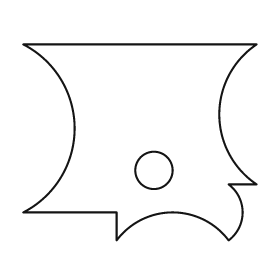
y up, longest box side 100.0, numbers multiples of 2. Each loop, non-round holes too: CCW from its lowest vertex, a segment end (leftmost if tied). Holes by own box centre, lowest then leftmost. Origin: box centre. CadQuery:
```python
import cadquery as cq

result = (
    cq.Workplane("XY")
    .moveTo(-10.0, -42.0)
    .threePointArc((14.0, -30.0), (38.0, -42.0))
    .threePointArc((44.0, -30.0), (38.0, -18.0))
    .lineTo(50.0, -18.0)
    .threePointArc((34.0, 12.0), (50.0, 42.0))
    .lineTo(-50.0, 42.0)
    .threePointArc((-28.0, 6.0), (-50.0, -30.0))
    .lineTo(-10.0, -30.0)
    .close()
    .moveTo(6.0, -12.0)
    .circle(8.0)
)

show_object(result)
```